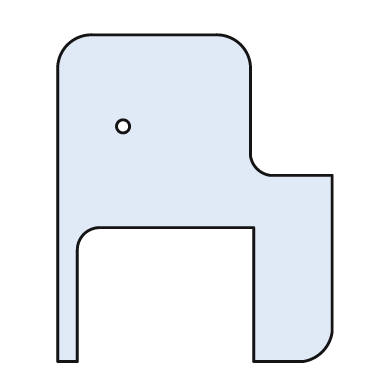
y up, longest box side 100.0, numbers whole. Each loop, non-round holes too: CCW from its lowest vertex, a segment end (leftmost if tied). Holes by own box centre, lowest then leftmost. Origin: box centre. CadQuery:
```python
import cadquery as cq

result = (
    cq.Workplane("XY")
    .moveTo(-42.0, -50.0)
    .lineTo(-36.0, -50.0)
    .lineTo(-36.0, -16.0)
    .threePointArc((-34.0, -11.0), (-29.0, -9.0))
    .lineTo(18.0, -9.0)
    .lineTo(18.0, -50.0)
    .lineTo(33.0, -50.0)
    .threePointArc((39.0, -47.0), (42.0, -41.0))
    .lineTo(42.0, 7.0)
    .lineTo(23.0, 7.0)
    .threePointArc((19.0, 9.0), (17.0, 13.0))
    .lineTo(17.0, 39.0)
    .threePointArc((14.0, 47.0), (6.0, 50.0))
    .lineTo(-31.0, 50.0)
    .threePointArc((-39.0, 47.0), (-42.0, 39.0))
    .close()
    .moveTo(-22.0, 22.0)
    .circle(2.0)
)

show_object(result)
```